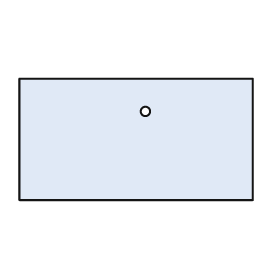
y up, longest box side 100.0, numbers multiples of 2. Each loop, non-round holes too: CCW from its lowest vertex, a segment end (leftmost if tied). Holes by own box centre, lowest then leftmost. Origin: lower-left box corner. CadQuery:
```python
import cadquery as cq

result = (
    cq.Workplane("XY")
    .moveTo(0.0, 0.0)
    .lineTo(100.0, 0.0)
    .lineTo(100.0, 52.0)
    .lineTo(0.0, 52.0)
    .close()
    .moveTo(54.0, 38.0)
    .circle(2.0)
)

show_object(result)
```